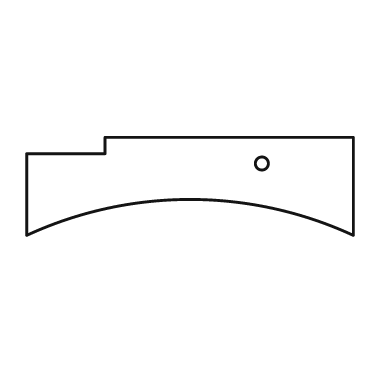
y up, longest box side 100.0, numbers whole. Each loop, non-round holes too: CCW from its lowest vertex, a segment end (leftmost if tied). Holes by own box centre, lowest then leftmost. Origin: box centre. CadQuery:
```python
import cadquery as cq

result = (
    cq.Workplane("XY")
    .moveTo(-50.0, -15.0)
    .threePointArc((0.0, -4.0), (50.0, -15.0))
    .lineTo(50.0, 15.0)
    .lineTo(-26.0, 15.0)
    .lineTo(-26.0, 10.0)
    .lineTo(-50.0, 10.0)
    .close()
    .moveTo(22.0, 7.0)
    .circle(2.0)
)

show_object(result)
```